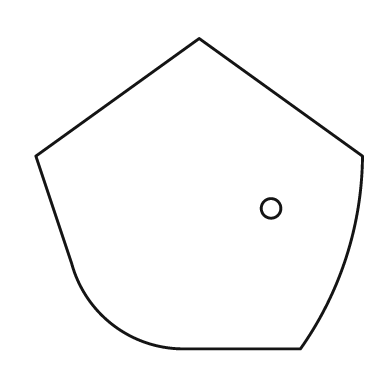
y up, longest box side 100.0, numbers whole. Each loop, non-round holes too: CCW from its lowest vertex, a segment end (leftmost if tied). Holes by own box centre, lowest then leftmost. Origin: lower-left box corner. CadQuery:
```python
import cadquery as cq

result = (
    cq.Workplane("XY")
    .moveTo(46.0, 0.0)
    .lineTo(81.0, 0.0)
    .threePointArc((95.0, 28.0), (100.0, 59.0))
    .lineTo(50.0, 95.0)
    .lineTo(0.0, 59.0)
    .lineTo(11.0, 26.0)
    .threePointArc((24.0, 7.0), (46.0, 0.0))
    .close()
    .moveTo(72.0, 43.0)
    .circle(3.0)
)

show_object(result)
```